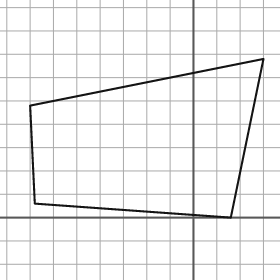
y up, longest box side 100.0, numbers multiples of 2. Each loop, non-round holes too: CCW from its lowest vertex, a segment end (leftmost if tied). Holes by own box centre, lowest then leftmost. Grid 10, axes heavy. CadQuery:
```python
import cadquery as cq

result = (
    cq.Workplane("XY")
    .moveTo(16.0, 0.0)
    .lineTo(30.0, 68.0)
    .lineTo(-70.0, 48.0)
    .lineTo(-68.0, 6.0)
    .close()
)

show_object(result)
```